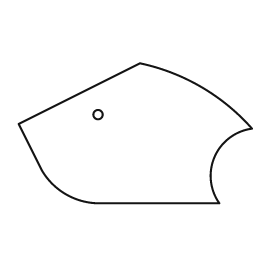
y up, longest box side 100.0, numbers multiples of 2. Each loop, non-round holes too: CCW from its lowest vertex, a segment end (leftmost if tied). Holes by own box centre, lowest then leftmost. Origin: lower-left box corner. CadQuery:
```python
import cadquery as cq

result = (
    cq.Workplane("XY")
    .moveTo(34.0, 0.0)
    .lineTo(86.0, 0.0)
    .threePointArc((84.0, 20.0), (100.0, 32.0))
    .threePointArc((78.0, 50.0), (52.0, 60.0))
    .lineTo(0.0, 34.0)
    .lineTo(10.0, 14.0)
    .threePointArc((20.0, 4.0), (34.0, 0.0))
    .close()
    .moveTo(34.0, 38.0)
    .circle(2.0)
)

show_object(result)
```